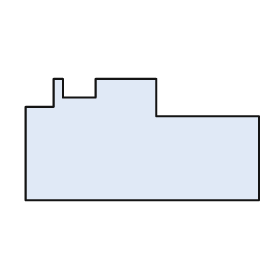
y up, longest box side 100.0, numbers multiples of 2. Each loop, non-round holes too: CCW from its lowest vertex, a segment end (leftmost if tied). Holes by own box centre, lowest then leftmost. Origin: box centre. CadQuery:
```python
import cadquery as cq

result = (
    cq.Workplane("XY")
    .moveTo(-50.0, -26.0)
    .lineTo(50.0, -26.0)
    .lineTo(50.0, 10.0)
    .lineTo(6.0, 10.0)
    .lineTo(6.0, 26.0)
    .lineTo(-20.0, 26.0)
    .lineTo(-20.0, 18.0)
    .lineTo(-34.0, 18.0)
    .lineTo(-34.0, 26.0)
    .lineTo(-38.0, 26.0)
    .lineTo(-38.0, 14.0)
    .lineTo(-50.0, 14.0)
    .close()
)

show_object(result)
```